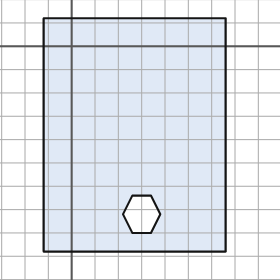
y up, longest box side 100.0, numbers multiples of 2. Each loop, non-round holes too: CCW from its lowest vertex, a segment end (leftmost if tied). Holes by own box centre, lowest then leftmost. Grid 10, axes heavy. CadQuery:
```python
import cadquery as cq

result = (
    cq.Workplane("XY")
    .moveTo(-12.0, -88.0)
    .lineTo(66.0, -88.0)
    .lineTo(66.0, 12.0)
    .lineTo(-12.0, 12.0)
    .close()
    .moveTo(26.0, -80.0)
    .lineTo(34.0, -80.0)
    .lineTo(38.0, -72.0)
    .lineTo(34.0, -64.0)
    .lineTo(26.0, -64.0)
    .lineTo(22.0, -72.0)
    .close()
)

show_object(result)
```